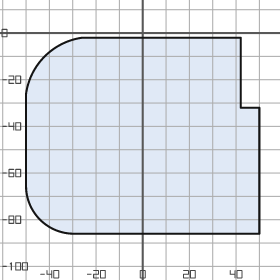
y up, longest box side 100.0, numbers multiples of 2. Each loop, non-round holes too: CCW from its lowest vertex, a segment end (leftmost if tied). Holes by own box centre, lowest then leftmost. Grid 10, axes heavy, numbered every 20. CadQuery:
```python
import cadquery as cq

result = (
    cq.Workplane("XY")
    .moveTo(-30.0, -86.0)
    .lineTo(50.0, -86.0)
    .lineTo(50.0, -32.0)
    .lineTo(42.0, -32.0)
    .lineTo(42.0, -2.0)
    .lineTo(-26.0, -2.0)
    .threePointArc((-42.0, -10.0), (-50.0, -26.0))
    .lineTo(-50.0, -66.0)
    .threePointArc((-44.0, -80.0), (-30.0, -86.0))
    .close()
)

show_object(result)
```